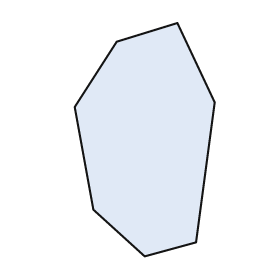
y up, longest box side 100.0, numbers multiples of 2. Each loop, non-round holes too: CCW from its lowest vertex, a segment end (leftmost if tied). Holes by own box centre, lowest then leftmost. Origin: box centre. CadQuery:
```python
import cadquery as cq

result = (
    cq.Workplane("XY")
    .moveTo(0.0, -50.0)
    .lineTo(22.0, -44.0)
    .lineTo(30.0, 16.0)
    .lineTo(14.0, 50.0)
    .lineTo(-12.0, 42.0)
    .lineTo(-30.0, 14.0)
    .lineTo(-22.0, -30.0)
    .close()
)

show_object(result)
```